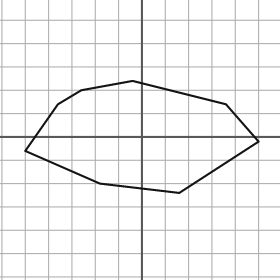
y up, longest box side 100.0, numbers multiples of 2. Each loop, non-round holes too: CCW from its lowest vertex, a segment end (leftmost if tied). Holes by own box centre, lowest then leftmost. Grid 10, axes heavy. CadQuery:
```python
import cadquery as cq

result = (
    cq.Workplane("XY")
    .moveTo(16.0, -24.0)
    .lineTo(50.0, -2.0)
    .lineTo(36.0, 14.0)
    .lineTo(-4.0, 24.0)
    .lineTo(-26.0, 20.0)
    .lineTo(-36.0, 14.0)
    .lineTo(-50.0, -6.0)
    .lineTo(-18.0, -20.0)
    .close()
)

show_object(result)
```